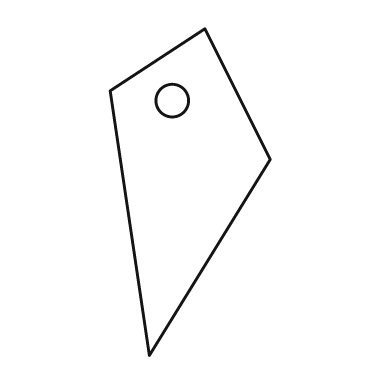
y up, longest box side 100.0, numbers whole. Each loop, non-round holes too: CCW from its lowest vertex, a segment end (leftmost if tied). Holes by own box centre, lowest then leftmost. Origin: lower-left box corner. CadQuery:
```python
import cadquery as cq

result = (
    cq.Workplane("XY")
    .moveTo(12.0, 0.0)
    .lineTo(49.0, 60.0)
    .lineTo(29.0, 100.0)
    .lineTo(0.0, 81.0)
    .close()
    .moveTo(19.0, 78.0)
    .circle(5.0)
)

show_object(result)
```